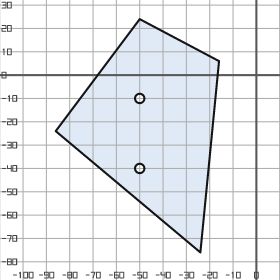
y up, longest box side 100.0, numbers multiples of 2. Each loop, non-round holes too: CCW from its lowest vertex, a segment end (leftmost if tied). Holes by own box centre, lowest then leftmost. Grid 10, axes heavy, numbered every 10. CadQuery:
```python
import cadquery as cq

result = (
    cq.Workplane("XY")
    .moveTo(-24.0, -76.0)
    .lineTo(-16.0, 6.0)
    .lineTo(-50.0, 24.0)
    .lineTo(-86.0, -24.0)
    .close()
    .moveTo(-50.0, -40.0)
    .circle(2.0)
    .moveTo(-50.0, -10.0)
    .circle(2.0)
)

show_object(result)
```